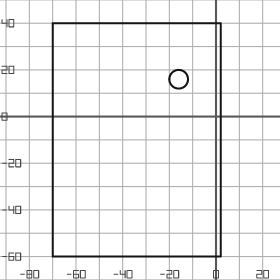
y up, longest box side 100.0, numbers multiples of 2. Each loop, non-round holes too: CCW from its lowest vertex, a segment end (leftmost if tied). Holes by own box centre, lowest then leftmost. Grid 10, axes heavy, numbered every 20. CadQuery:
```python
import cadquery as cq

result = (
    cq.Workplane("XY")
    .moveTo(-70.0, -60.0)
    .lineTo(2.0, -60.0)
    .lineTo(2.0, 40.0)
    .lineTo(-70.0, 40.0)
    .close()
    .moveTo(-16.0, 16.0)
    .circle(4.0)
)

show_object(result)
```